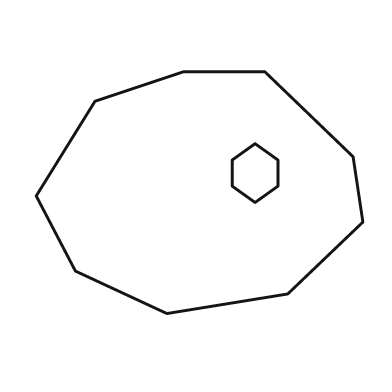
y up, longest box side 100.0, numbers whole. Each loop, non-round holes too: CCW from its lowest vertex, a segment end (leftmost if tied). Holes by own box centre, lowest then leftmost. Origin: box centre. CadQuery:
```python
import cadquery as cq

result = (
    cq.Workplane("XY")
    .moveTo(-10.0, -37.0)
    .lineTo(27.0, -31.0)
    .lineTo(50.0, -9.0)
    .lineTo(47.0, 11.0)
    .lineTo(20.0, 37.0)
    .lineTo(-5.0, 37.0)
    .lineTo(-32.0, 28.0)
    .lineTo(-50.0, -1.0)
    .lineTo(-38.0, -24.0)
    .close()
    .moveTo(17.0, -3.0)
    .lineTo(24.0, 2.0)
    .lineTo(24.0, 10.0)
    .lineTo(17.0, 15.0)
    .lineTo(10.0, 10.0)
    .lineTo(10.0, 2.0)
    .close()
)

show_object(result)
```